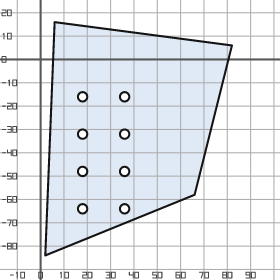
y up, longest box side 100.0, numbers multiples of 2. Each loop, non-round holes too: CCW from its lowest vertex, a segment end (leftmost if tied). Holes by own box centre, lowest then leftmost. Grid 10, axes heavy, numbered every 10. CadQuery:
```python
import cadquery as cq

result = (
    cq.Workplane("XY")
    .moveTo(2.0, -84.0)
    .lineTo(66.0, -58.0)
    .lineTo(82.0, 6.0)
    .lineTo(6.0, 16.0)
    .close()
    .moveTo(18.0, -64.0)
    .circle(2.0)
    .moveTo(36.0, -64.0)
    .circle(2.0)
    .moveTo(18.0, -48.0)
    .circle(2.0)
    .moveTo(36.0, -48.0)
    .circle(2.0)
    .moveTo(18.0, -32.0)
    .circle(2.0)
    .moveTo(36.0, -32.0)
    .circle(2.0)
    .moveTo(18.0, -16.0)
    .circle(2.0)
    .moveTo(36.0, -16.0)
    .circle(2.0)
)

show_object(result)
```